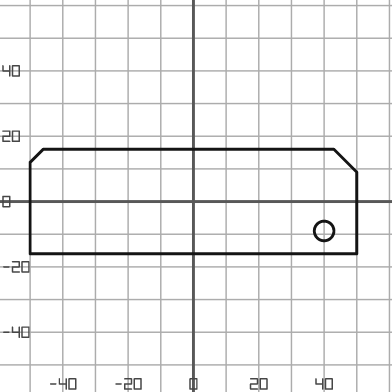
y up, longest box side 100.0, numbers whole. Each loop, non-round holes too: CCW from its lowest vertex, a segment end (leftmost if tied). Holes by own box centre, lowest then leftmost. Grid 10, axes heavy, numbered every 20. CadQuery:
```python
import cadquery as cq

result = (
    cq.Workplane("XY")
    .moveTo(-50.0, -16.0)
    .lineTo(50.0, -16.0)
    .lineTo(50.0, 9.0)
    .lineTo(43.0, 16.0)
    .lineTo(-46.0, 16.0)
    .lineTo(-50.0, 12.0)
    .close()
    .moveTo(40.0, -9.0)
    .circle(3.0)
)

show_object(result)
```